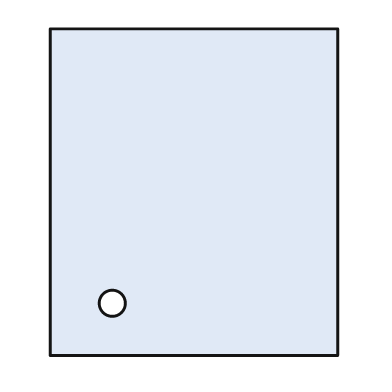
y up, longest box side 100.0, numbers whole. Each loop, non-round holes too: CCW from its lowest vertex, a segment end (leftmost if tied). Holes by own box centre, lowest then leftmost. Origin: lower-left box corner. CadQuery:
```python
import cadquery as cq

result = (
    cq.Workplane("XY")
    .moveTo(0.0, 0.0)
    .lineTo(88.0, 0.0)
    .lineTo(88.0, 100.0)
    .lineTo(0.0, 100.0)
    .close()
    .moveTo(19.0, 16.0)
    .circle(4.0)
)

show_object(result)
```